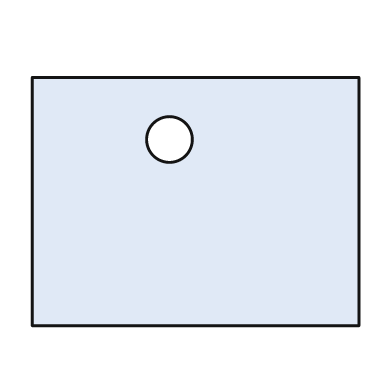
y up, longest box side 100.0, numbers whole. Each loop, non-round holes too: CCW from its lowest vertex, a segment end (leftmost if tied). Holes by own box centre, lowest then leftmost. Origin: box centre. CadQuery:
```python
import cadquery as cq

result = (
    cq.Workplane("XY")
    .moveTo(-50.0, -38.0)
    .lineTo(50.0, -38.0)
    .lineTo(50.0, 38.0)
    .lineTo(-50.0, 38.0)
    .close()
    .moveTo(-8.0, 19.0)
    .circle(7.0)
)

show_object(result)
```